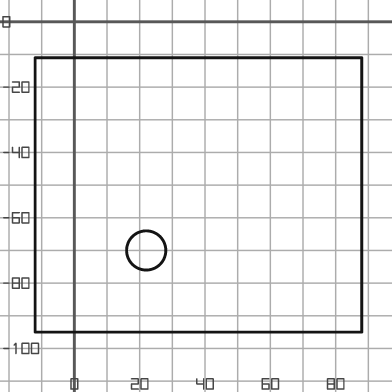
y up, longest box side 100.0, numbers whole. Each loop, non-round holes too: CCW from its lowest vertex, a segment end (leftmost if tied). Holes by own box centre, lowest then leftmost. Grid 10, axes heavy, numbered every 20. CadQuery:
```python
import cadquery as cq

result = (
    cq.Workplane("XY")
    .moveTo(-12.0, -95.0)
    .lineTo(88.0, -95.0)
    .lineTo(88.0, -11.0)
    .lineTo(-12.0, -11.0)
    .close()
    .moveTo(22.0, -70.0)
    .circle(6.0)
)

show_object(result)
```